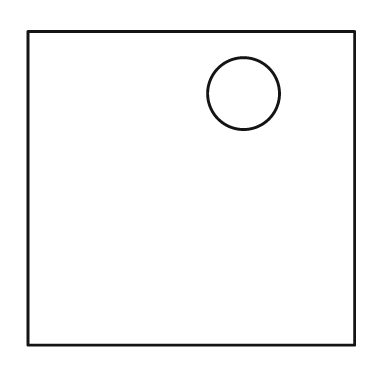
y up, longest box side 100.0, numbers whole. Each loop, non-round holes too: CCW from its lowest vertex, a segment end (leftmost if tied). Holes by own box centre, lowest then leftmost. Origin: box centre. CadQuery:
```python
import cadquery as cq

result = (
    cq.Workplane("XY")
    .moveTo(-50.0, -48.0)
    .lineTo(50.0, -48.0)
    .lineTo(50.0, 48.0)
    .lineTo(-50.0, 48.0)
    .close()
    .moveTo(16.0, 29.0)
    .circle(11.0)
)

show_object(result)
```